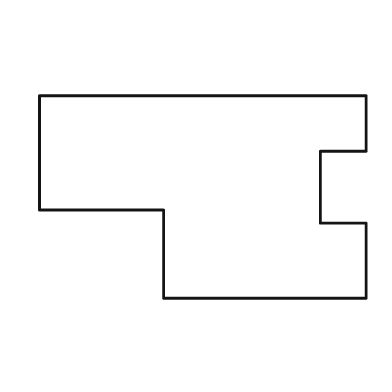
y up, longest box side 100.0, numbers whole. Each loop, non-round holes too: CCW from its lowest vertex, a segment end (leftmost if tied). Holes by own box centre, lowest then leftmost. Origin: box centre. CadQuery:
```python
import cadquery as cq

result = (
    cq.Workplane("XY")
    .moveTo(-12.0, -31.0)
    .lineTo(50.0, -31.0)
    .lineTo(50.0, -8.0)
    .lineTo(36.0, -8.0)
    .lineTo(36.0, 14.0)
    .lineTo(50.0, 14.0)
    .lineTo(50.0, 31.0)
    .lineTo(-50.0, 31.0)
    .lineTo(-50.0, -4.0)
    .lineTo(-12.0, -4.0)
    .close()
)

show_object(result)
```